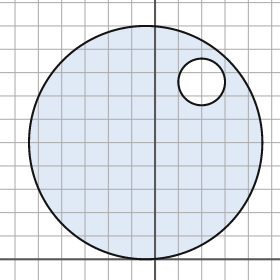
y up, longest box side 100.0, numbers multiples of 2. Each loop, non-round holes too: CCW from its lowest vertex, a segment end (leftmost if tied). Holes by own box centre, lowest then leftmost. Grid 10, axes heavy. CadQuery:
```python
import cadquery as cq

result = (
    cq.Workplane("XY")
    .moveTo(-4.0, 50.0)
    .circle(50.0)
    .moveTo(20.0, 76.0)
    .circle(10.0)
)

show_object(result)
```